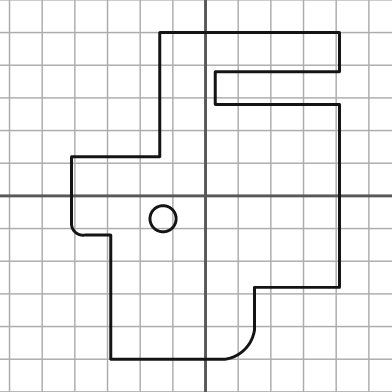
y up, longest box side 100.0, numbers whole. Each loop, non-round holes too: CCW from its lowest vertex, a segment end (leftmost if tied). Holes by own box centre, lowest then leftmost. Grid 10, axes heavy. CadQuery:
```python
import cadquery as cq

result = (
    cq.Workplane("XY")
    .moveTo(-29.0, -50.0)
    .lineTo(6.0, -50.0)
    .threePointArc((12.0, -47.0), (15.0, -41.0))
    .lineTo(15.0, -28.0)
    .lineTo(41.0, -28.0)
    .lineTo(41.0, 28.0)
    .lineTo(3.0, 28.0)
    .lineTo(3.0, 38.0)
    .lineTo(41.0, 38.0)
    .lineTo(41.0, 50.0)
    .lineTo(-14.0, 50.0)
    .lineTo(-14.0, 12.0)
    .lineTo(-41.0, 12.0)
    .lineTo(-41.0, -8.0)
    .threePointArc((-40.0, -11.0), (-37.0, -12.0))
    .lineTo(-29.0, -12.0)
    .close()
    .moveTo(-13.0, -7.0)
    .circle(4.0)
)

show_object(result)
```